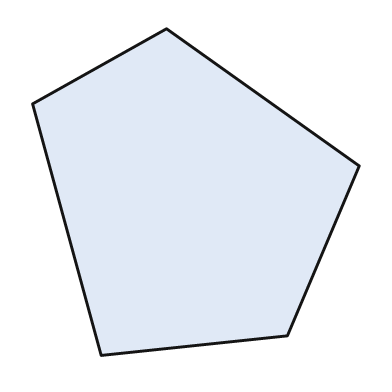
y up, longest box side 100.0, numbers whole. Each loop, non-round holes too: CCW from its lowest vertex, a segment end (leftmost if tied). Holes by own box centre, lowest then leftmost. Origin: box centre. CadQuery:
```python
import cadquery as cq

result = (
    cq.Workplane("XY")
    .moveTo(-29.0, -50.0)
    .lineTo(28.0, -44.0)
    .lineTo(50.0, 8.0)
    .lineTo(-9.0, 50.0)
    .lineTo(-50.0, 27.0)
    .close()
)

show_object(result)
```